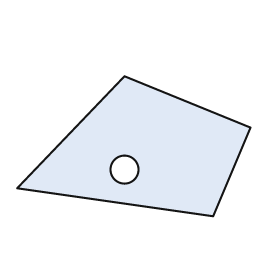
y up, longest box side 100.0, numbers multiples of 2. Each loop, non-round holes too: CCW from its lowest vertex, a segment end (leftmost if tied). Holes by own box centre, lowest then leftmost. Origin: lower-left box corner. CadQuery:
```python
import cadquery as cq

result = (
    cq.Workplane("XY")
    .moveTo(84.0, 0.0)
    .lineTo(100.0, 38.0)
    .lineTo(46.0, 60.0)
    .lineTo(0.0, 12.0)
    .close()
    .moveTo(46.0, 20.0)
    .circle(6.0)
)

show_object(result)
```